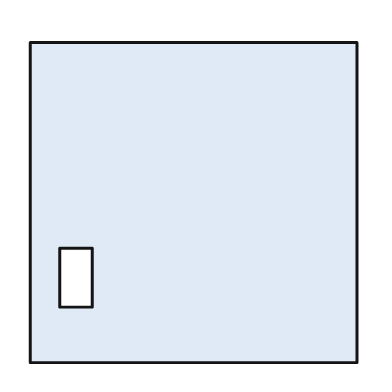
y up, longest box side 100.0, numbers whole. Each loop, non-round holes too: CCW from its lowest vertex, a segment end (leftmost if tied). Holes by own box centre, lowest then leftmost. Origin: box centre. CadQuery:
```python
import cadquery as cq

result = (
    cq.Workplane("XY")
    .moveTo(-50.0, -49.0)
    .lineTo(50.0, -49.0)
    .lineTo(50.0, 49.0)
    .lineTo(-50.0, 49.0)
    .close()
    .moveTo(-41.0, -32.0)
    .lineTo(-31.0, -32.0)
    .lineTo(-31.0, -14.0)
    .lineTo(-41.0, -14.0)
    .close()
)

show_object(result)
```